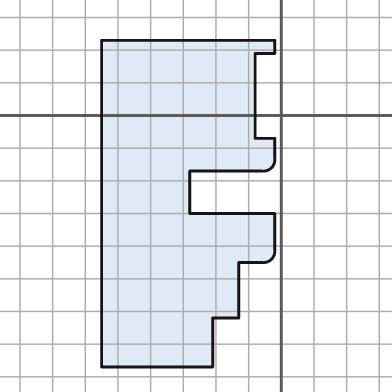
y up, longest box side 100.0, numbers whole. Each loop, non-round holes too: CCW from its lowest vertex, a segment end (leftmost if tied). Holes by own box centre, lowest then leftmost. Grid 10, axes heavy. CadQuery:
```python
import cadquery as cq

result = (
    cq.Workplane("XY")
    .moveTo(-55.0, -77.0)
    .lineTo(-21.0, -77.0)
    .lineTo(-21.0, -62.0)
    .lineTo(-13.0, -62.0)
    .lineTo(-13.0, -45.0)
    .lineTo(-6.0, -45.0)
    .threePointArc((-3.0, -44.0), (-2.0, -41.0))
    .lineTo(-2.0, -30.0)
    .lineTo(-28.0, -30.0)
    .lineTo(-28.0, -17.0)
    .lineTo(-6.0, -17.0)
    .threePointArc((-3.0, -16.0), (-2.0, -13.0))
    .lineTo(-2.0, -7.0)
    .lineTo(-8.0, -7.0)
    .lineTo(-8.0, 19.0)
    .lineTo(-2.0, 19.0)
    .lineTo(-2.0, 23.0)
    .lineTo(-55.0, 23.0)
    .close()
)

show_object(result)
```